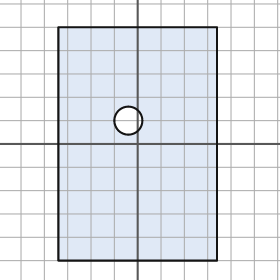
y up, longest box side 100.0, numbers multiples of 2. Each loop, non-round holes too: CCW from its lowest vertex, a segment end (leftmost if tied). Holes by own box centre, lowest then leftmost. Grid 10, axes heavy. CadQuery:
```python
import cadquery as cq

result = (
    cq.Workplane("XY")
    .moveTo(-34.0, -50.0)
    .lineTo(34.0, -50.0)
    .lineTo(34.0, 50.0)
    .lineTo(-34.0, 50.0)
    .close()
    .moveTo(-4.0, 10.0)
    .circle(6.0)
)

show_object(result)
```